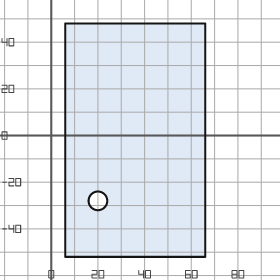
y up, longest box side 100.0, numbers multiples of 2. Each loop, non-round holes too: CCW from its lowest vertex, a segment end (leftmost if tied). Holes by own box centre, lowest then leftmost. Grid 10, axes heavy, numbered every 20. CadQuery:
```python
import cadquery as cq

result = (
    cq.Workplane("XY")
    .moveTo(6.0, -52.0)
    .lineTo(66.0, -52.0)
    .lineTo(66.0, 48.0)
    .lineTo(6.0, 48.0)
    .close()
    .moveTo(20.0, -28.0)
    .circle(4.0)
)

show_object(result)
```